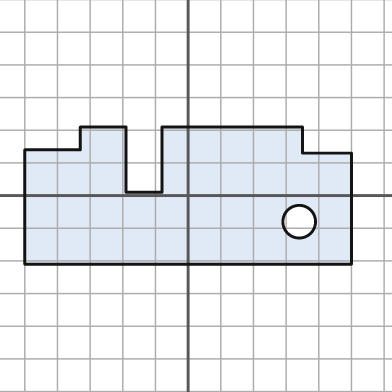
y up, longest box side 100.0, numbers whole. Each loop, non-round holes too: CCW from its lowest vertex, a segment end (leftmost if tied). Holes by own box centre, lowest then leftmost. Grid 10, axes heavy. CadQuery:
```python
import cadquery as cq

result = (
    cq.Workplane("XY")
    .moveTo(-50.0, -21.0)
    .lineTo(50.0, -21.0)
    .lineTo(50.0, 13.0)
    .lineTo(35.0, 13.0)
    .lineTo(35.0, 21.0)
    .lineTo(-8.0, 21.0)
    .lineTo(-8.0, 1.0)
    .lineTo(-19.0, 1.0)
    .lineTo(-19.0, 21.0)
    .lineTo(-33.0, 21.0)
    .lineTo(-33.0, 14.0)
    .lineTo(-50.0, 14.0)
    .close()
    .moveTo(34.0, -8.0)
    .circle(5.0)
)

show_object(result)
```